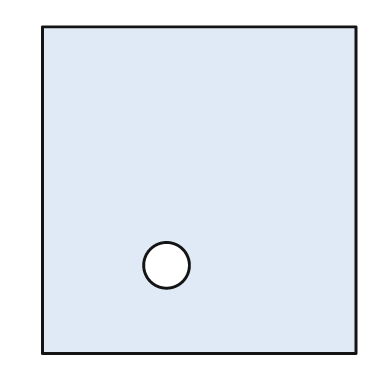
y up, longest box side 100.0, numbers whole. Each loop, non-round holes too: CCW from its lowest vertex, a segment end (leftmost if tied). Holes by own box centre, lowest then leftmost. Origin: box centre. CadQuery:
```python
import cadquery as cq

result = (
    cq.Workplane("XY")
    .moveTo(-48.0, -50.0)
    .lineTo(48.0, -50.0)
    .lineTo(48.0, 50.0)
    .lineTo(-48.0, 50.0)
    .close()
    .moveTo(-10.0, -23.0)
    .circle(7.0)
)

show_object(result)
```